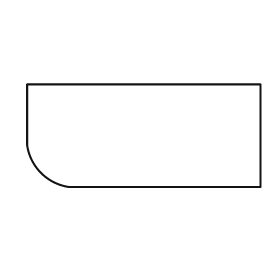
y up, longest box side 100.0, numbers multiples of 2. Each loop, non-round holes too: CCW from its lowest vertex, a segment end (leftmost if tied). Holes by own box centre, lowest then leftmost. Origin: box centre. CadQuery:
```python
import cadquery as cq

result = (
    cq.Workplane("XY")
    .moveTo(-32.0, -22.0)
    .lineTo(50.0, -22.0)
    .lineTo(50.0, 22.0)
    .lineTo(-50.0, 22.0)
    .lineTo(-50.0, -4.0)
    .threePointArc((-44.0, -16.0), (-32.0, -22.0))
    .close()
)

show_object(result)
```